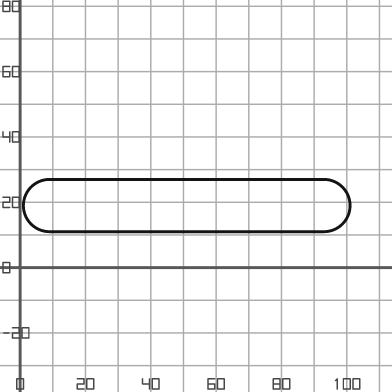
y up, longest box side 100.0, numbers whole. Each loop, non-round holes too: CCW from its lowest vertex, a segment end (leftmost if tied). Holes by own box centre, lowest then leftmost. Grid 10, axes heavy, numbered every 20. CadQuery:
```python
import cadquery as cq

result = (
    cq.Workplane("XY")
    .moveTo(9.0, 11.0)
    .lineTo(93.0, 11.0)
    .threePointArc((101.0, 19.0), (93.0, 27.0))
    .lineTo(9.0, 27.0)
    .threePointArc((1.0, 19.0), (9.0, 11.0))
    .close()
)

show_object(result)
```